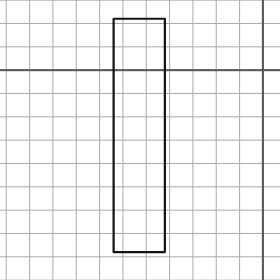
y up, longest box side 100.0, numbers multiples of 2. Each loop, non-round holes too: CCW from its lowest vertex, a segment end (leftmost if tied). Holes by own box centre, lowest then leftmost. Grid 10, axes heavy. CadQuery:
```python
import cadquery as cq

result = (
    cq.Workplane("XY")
    .moveTo(-64.0, -78.0)
    .lineTo(-42.0, -78.0)
    .lineTo(-42.0, 22.0)
    .lineTo(-64.0, 22.0)
    .close()
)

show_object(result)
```